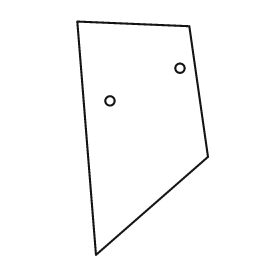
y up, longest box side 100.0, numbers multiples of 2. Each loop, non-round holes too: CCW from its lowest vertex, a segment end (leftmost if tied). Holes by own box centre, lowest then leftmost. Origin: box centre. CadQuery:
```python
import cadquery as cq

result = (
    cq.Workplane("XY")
    .moveTo(-20.0, -50.0)
    .lineTo(28.0, -8.0)
    .lineTo(20.0, 48.0)
    .lineTo(-28.0, 50.0)
    .close()
    .moveTo(-14.0, 16.0)
    .circle(2.0)
    .moveTo(16.0, 30.0)
    .circle(2.0)
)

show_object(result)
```